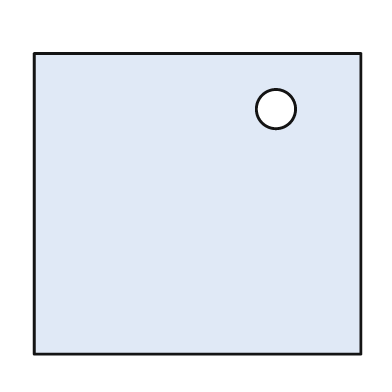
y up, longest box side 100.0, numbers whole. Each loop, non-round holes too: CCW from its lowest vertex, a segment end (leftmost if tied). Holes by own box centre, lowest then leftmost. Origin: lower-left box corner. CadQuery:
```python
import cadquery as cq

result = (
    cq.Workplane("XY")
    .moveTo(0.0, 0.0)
    .lineTo(100.0, 0.0)
    .lineTo(100.0, 92.0)
    .lineTo(0.0, 92.0)
    .close()
    .moveTo(74.0, 75.0)
    .circle(6.0)
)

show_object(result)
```